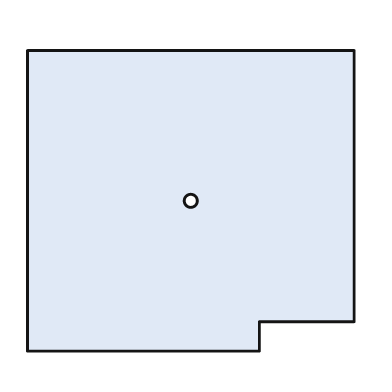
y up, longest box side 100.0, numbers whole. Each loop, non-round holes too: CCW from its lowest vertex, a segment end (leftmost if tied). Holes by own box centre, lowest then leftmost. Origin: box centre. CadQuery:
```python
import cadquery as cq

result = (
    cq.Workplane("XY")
    .moveTo(-50.0, -46.0)
    .lineTo(21.0, -46.0)
    .lineTo(21.0, -37.0)
    .lineTo(50.0, -37.0)
    .lineTo(50.0, 46.0)
    .lineTo(-50.0, 46.0)
    .close()
    .moveTo(0.0, 0.0)
    .circle(2.0)
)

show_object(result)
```